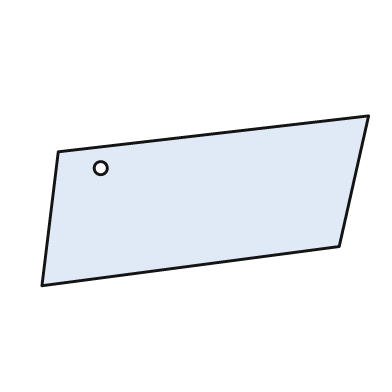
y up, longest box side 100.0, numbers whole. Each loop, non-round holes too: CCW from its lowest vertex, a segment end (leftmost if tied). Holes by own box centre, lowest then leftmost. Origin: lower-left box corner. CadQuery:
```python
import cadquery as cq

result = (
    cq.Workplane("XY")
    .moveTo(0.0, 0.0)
    .lineTo(91.0, 12.0)
    .lineTo(100.0, 52.0)
    .lineTo(5.0, 41.0)
    .close()
    .moveTo(18.0, 36.0)
    .circle(2.0)
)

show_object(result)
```